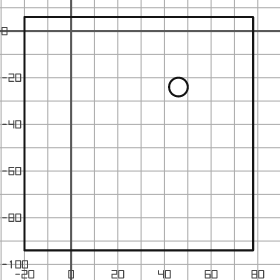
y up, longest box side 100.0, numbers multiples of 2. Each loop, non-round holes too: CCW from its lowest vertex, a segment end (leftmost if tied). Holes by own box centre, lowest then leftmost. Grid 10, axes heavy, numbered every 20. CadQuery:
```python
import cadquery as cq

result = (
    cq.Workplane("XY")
    .moveTo(-20.0, -94.0)
    .lineTo(78.0, -94.0)
    .lineTo(78.0, 6.0)
    .lineTo(-20.0, 6.0)
    .close()
    .moveTo(46.0, -24.0)
    .circle(4.0)
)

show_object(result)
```